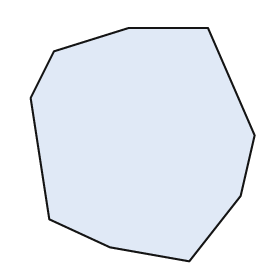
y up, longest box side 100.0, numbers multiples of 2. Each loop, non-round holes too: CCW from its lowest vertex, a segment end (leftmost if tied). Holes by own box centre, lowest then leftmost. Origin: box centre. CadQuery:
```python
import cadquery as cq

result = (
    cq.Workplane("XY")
    .moveTo(20.0, -50.0)
    .lineTo(42.0, -22.0)
    .lineTo(48.0, 4.0)
    .lineTo(28.0, 50.0)
    .lineTo(-6.0, 50.0)
    .lineTo(-38.0, 40.0)
    .lineTo(-48.0, 20.0)
    .lineTo(-40.0, -32.0)
    .lineTo(-14.0, -44.0)
    .close()
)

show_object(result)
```